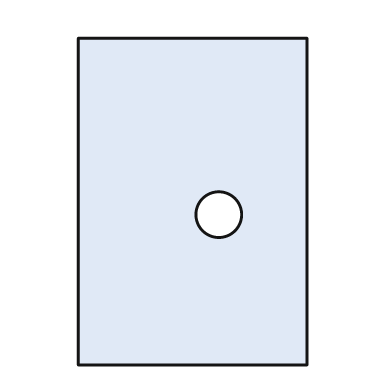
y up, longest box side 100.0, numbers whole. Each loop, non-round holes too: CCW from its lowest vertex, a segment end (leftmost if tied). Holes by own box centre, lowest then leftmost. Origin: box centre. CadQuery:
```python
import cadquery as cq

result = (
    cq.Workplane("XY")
    .moveTo(-35.0, -50.0)
    .lineTo(35.0, -50.0)
    .lineTo(35.0, 50.0)
    .lineTo(-35.0, 50.0)
    .close()
    .moveTo(8.0, -4.0)
    .circle(7.0)
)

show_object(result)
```